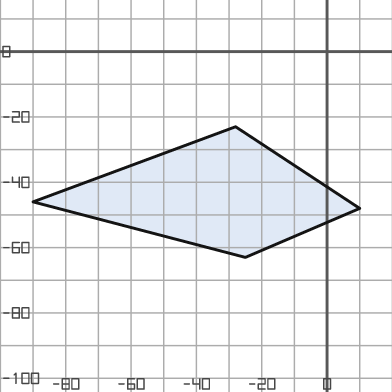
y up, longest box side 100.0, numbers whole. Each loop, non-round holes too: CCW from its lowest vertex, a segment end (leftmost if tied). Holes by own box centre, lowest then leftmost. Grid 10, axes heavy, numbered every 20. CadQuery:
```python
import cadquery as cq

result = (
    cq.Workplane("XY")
    .moveTo(-25.0, -63.0)
    .lineTo(10.0, -48.0)
    .lineTo(-28.0, -23.0)
    .lineTo(-90.0, -46.0)
    .close()
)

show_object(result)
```